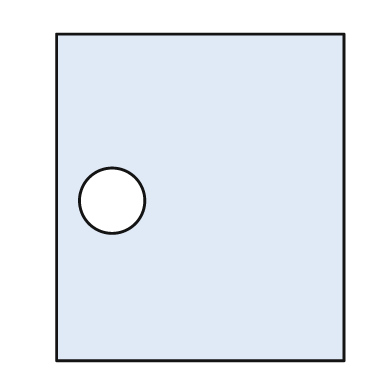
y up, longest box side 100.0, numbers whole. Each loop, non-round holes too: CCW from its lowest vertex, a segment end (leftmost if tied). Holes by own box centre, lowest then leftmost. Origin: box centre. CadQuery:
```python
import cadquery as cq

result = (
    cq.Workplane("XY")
    .moveTo(-44.0, -50.0)
    .lineTo(44.0, -50.0)
    .lineTo(44.0, 50.0)
    .lineTo(-44.0, 50.0)
    .close()
    .moveTo(-27.0, -1.0)
    .circle(10.0)
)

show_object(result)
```